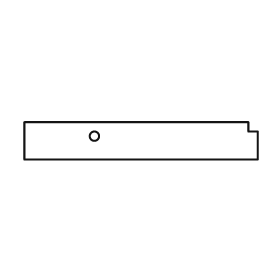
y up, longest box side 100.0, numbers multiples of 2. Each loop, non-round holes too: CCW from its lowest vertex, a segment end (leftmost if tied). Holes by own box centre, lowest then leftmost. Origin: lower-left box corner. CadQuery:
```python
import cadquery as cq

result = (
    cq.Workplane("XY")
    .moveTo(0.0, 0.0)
    .lineTo(100.0, 0.0)
    .lineTo(100.0, 12.0)
    .lineTo(96.0, 12.0)
    .lineTo(96.0, 16.0)
    .lineTo(0.0, 16.0)
    .close()
    .moveTo(30.0, 10.0)
    .circle(2.0)
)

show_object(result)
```